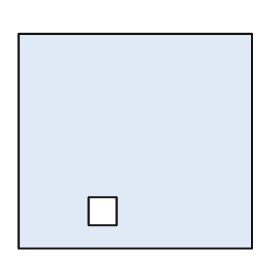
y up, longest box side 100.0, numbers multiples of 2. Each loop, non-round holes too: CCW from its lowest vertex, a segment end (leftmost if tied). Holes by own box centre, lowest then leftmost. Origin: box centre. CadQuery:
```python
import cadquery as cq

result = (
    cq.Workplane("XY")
    .moveTo(-50.0, -46.0)
    .lineTo(50.0, -46.0)
    .lineTo(50.0, 46.0)
    .lineTo(-50.0, 46.0)
    .close()
    .moveTo(-20.0, -36.0)
    .lineTo(-8.0, -36.0)
    .lineTo(-8.0, -24.0)
    .lineTo(-20.0, -24.0)
    .close()
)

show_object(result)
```